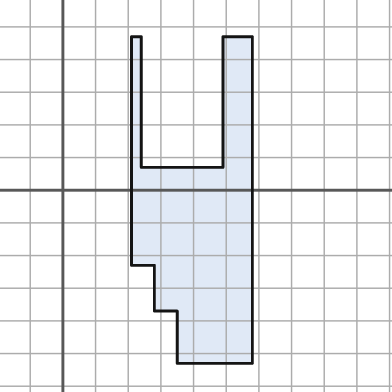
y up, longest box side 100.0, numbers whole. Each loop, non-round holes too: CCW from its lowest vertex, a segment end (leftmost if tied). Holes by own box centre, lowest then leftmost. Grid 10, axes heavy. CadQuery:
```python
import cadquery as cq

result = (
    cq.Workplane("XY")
    .moveTo(35.0, -53.0)
    .lineTo(58.0, -53.0)
    .lineTo(58.0, 47.0)
    .lineTo(49.0, 47.0)
    .lineTo(49.0, 7.0)
    .lineTo(24.0, 7.0)
    .lineTo(24.0, 47.0)
    .lineTo(21.0, 47.0)
    .lineTo(21.0, -23.0)
    .lineTo(28.0, -23.0)
    .lineTo(28.0, -37.0)
    .lineTo(35.0, -37.0)
    .close()
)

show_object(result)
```